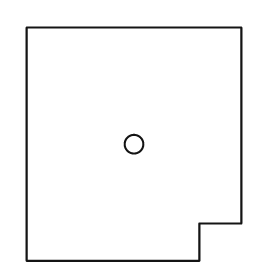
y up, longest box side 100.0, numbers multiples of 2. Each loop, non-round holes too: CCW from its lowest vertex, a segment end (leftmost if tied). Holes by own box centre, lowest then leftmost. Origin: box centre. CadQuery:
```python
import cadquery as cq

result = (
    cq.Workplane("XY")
    .moveTo(-46.0, -50.0)
    .lineTo(28.0, -50.0)
    .lineTo(28.0, -34.0)
    .lineTo(46.0, -34.0)
    .lineTo(46.0, 50.0)
    .lineTo(-46.0, 50.0)
    .close()
    .moveTo(0.0, 0.0)
    .circle(4.0)
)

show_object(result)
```